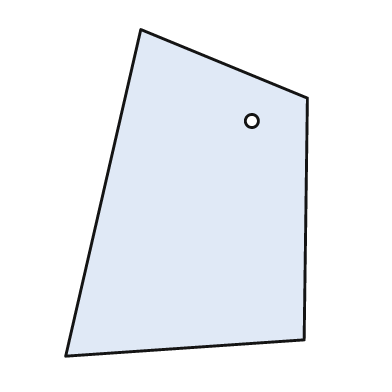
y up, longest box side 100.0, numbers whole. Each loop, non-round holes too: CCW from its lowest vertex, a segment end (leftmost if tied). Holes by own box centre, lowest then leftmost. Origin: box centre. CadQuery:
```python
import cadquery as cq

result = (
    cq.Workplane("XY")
    .moveTo(-37.0, -50.0)
    .lineTo(36.0, -45.0)
    .lineTo(37.0, 29.0)
    .lineTo(-14.0, 50.0)
    .close()
    .moveTo(20.0, 22.0)
    .circle(2.0)
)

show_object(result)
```